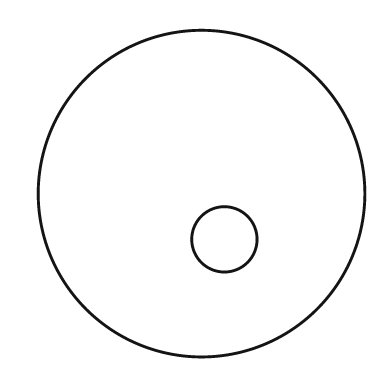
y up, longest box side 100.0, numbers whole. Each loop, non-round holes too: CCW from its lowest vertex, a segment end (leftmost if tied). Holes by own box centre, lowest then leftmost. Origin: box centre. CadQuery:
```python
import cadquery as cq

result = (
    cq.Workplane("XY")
    .moveTo(0.0, 0.0)
    .circle(50.0)
    .moveTo(7.0, -14.0)
    .circle(10.0)
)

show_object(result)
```